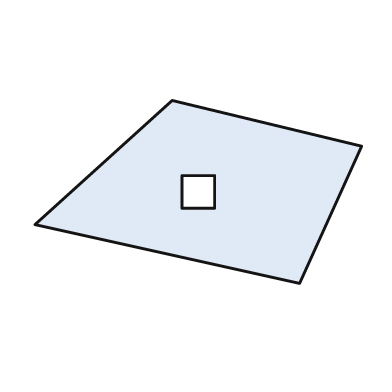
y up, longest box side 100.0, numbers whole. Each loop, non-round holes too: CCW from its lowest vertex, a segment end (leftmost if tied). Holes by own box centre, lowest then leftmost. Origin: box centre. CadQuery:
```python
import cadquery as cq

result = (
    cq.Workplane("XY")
    .moveTo(31.0, -28.0)
    .lineTo(50.0, 14.0)
    .lineTo(-8.0, 28.0)
    .lineTo(-50.0, -10.0)
    .close()
    .moveTo(-5.0, -5.0)
    .lineTo(5.0, -5.0)
    .lineTo(5.0, 5.0)
    .lineTo(-5.0, 5.0)
    .close()
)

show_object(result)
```